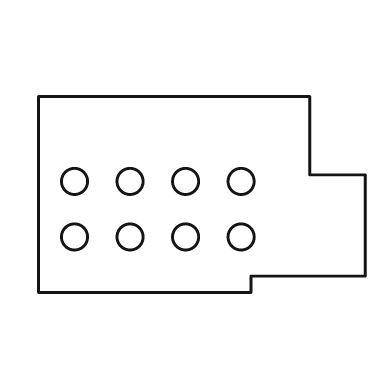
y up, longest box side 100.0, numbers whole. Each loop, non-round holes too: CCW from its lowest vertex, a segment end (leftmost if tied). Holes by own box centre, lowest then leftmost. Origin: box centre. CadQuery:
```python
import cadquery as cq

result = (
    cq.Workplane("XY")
    .moveTo(-50.0, -30.0)
    .lineTo(15.0, -30.0)
    .lineTo(15.0, -25.0)
    .lineTo(50.0, -25.0)
    .lineTo(50.0, 6.0)
    .lineTo(33.0, 6.0)
    .lineTo(33.0, 30.0)
    .lineTo(-50.0, 30.0)
    .close()
    .moveTo(-39.0, -13.0)
    .circle(4.0)
    .moveTo(-22.0, -13.0)
    .circle(4.0)
    .moveTo(-5.0, -13.0)
    .circle(4.0)
    .moveTo(12.0, -13.0)
    .circle(4.0)
    .moveTo(-39.0, 4.0)
    .circle(4.0)
    .moveTo(-22.0, 4.0)
    .circle(4.0)
    .moveTo(-5.0, 4.0)
    .circle(4.0)
    .moveTo(12.0, 4.0)
    .circle(4.0)
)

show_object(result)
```